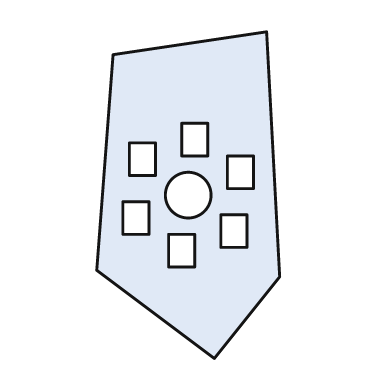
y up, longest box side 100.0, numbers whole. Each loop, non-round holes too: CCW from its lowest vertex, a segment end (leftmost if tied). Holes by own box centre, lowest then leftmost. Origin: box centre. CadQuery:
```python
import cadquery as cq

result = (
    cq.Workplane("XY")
    .moveTo(8.0, -50.0)
    .lineTo(28.0, -25.0)
    .lineTo(24.0, 50.0)
    .lineTo(-23.0, 43.0)
    .lineTo(-28.0, -23.0)
    .close()
    .moveTo(-6.0, -22.0)
    .lineTo(2.0, -22.0)
    .lineTo(2.0, -12.0)
    .lineTo(-6.0, -12.0)
    .close()
    .moveTo(10.0, -16.0)
    .lineTo(18.0, -16.0)
    .lineTo(18.0, -6.0)
    .lineTo(10.0, -6.0)
    .close()
    .moveTo(-20.0, -12.0)
    .lineTo(-12.0, -12.0)
    .lineTo(-12.0, -2.0)
    .lineTo(-20.0, -2.0)
    .close()
    .moveTo(0.0, 0.0)
    .circle(7.0)
    .moveTo(12.0, 2.0)
    .lineTo(20.0, 2.0)
    .lineTo(20.0, 12.0)
    .lineTo(12.0, 12.0)
    .close()
    .moveTo(-18.0, 6.0)
    .lineTo(-10.0, 6.0)
    .lineTo(-10.0, 16.0)
    .lineTo(-18.0, 16.0)
    .close()
    .moveTo(-2.0, 12.0)
    .lineTo(6.0, 12.0)
    .lineTo(6.0, 22.0)
    .lineTo(-2.0, 22.0)
    .close()
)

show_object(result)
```